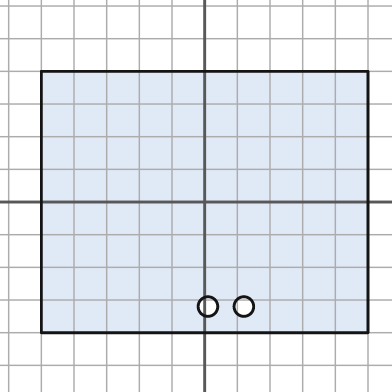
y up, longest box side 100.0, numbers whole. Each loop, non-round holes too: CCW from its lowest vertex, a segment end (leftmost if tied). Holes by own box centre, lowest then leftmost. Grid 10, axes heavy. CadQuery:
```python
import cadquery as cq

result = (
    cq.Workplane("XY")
    .moveTo(-50.0, -40.0)
    .lineTo(50.0, -40.0)
    .lineTo(50.0, 40.0)
    .lineTo(-50.0, 40.0)
    .close()
    .moveTo(1.0, -32.0)
    .circle(3.0)
    .moveTo(12.0, -32.0)
    .circle(3.0)
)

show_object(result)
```